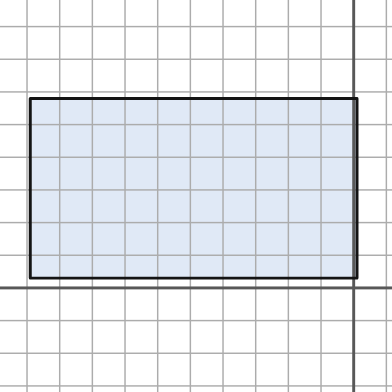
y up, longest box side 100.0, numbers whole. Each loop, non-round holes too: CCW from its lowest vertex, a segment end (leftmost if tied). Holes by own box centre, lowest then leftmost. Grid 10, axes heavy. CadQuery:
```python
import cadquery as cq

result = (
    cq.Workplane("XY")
    .moveTo(-99.0, 3.0)
    .lineTo(1.0, 3.0)
    .lineTo(1.0, 58.0)
    .lineTo(-99.0, 58.0)
    .close()
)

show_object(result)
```